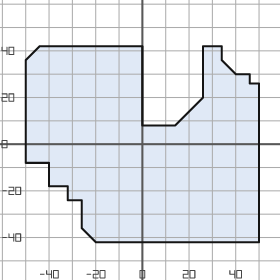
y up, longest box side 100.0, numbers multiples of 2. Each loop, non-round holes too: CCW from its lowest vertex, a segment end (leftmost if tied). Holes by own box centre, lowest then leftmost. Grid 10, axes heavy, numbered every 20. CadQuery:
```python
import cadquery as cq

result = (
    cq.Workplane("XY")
    .moveTo(-20.0, -42.0)
    .lineTo(50.0, -42.0)
    .lineTo(50.0, 26.0)
    .lineTo(46.0, 26.0)
    .lineTo(46.0, 30.0)
    .lineTo(40.0, 30.0)
    .lineTo(34.0, 36.0)
    .lineTo(34.0, 42.0)
    .lineTo(26.0, 42.0)
    .lineTo(26.0, 20.0)
    .lineTo(14.0, 8.0)
    .lineTo(0.0, 8.0)
    .lineTo(0.0, 42.0)
    .lineTo(-44.0, 42.0)
    .lineTo(-50.0, 36.0)
    .lineTo(-50.0, -8.0)
    .lineTo(-40.0, -8.0)
    .lineTo(-40.0, -18.0)
    .lineTo(-32.0, -18.0)
    .lineTo(-32.0, -24.0)
    .lineTo(-26.0, -24.0)
    .lineTo(-26.0, -36.0)
    .close()
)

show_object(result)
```